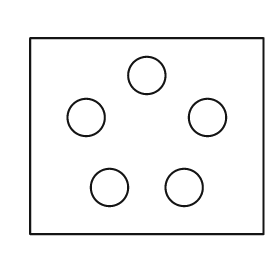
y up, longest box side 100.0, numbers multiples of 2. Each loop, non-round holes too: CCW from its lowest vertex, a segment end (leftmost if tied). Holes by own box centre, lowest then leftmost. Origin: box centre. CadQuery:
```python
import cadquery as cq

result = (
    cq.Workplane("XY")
    .moveTo(-50.0, -42.0)
    .lineTo(50.0, -42.0)
    .lineTo(50.0, 42.0)
    .lineTo(-50.0, 42.0)
    .close()
    .moveTo(-16.0, -22.0)
    .circle(8.0)
    .moveTo(16.0, -22.0)
    .circle(8.0)
    .moveTo(-26.0, 8.0)
    .circle(8.0)
    .moveTo(26.0, 8.0)
    .circle(8.0)
    .moveTo(0.0, 26.0)
    .circle(8.0)
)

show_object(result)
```